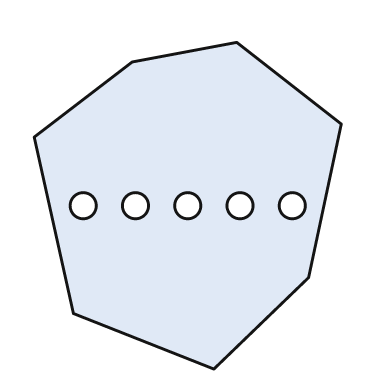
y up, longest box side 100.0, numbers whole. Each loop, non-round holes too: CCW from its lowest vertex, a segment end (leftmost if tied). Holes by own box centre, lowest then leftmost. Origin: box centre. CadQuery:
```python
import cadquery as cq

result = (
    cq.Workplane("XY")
    .moveTo(8.0, -50.0)
    .lineTo(37.0, -22.0)
    .lineTo(47.0, 25.0)
    .lineTo(15.0, 50.0)
    .lineTo(-17.0, 44.0)
    .lineTo(-47.0, 21.0)
    .lineTo(-35.0, -33.0)
    .close()
    .moveTo(-32.0, 0.0)
    .circle(4.0)
    .moveTo(-16.0, 0.0)
    .circle(4.0)
    .moveTo(0.0, 0.0)
    .circle(4.0)
    .moveTo(16.0, 0.0)
    .circle(4.0)
    .moveTo(32.0, 0.0)
    .circle(4.0)
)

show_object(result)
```